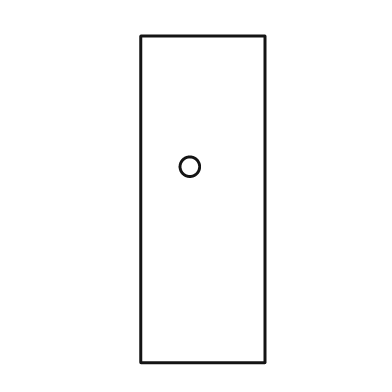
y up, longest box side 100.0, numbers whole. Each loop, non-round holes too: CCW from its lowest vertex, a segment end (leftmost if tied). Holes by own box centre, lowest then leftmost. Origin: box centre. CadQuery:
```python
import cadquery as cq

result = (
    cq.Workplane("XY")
    .moveTo(-19.0, -50.0)
    .lineTo(19.0, -50.0)
    .lineTo(19.0, 50.0)
    .lineTo(-19.0, 50.0)
    .close()
    .moveTo(-4.0, 10.0)
    .circle(3.0)
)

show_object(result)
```